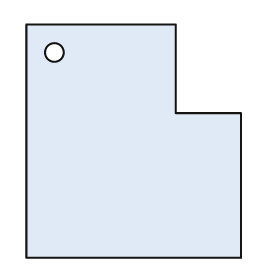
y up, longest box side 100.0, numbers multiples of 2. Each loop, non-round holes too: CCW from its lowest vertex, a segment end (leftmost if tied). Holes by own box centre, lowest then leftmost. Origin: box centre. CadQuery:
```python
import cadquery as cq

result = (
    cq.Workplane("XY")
    .moveTo(-46.0, -50.0)
    .lineTo(46.0, -50.0)
    .lineTo(46.0, 12.0)
    .lineTo(18.0, 12.0)
    .lineTo(18.0, 50.0)
    .lineTo(-46.0, 50.0)
    .close()
    .moveTo(-34.0, 38.0)
    .circle(4.0)
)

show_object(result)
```